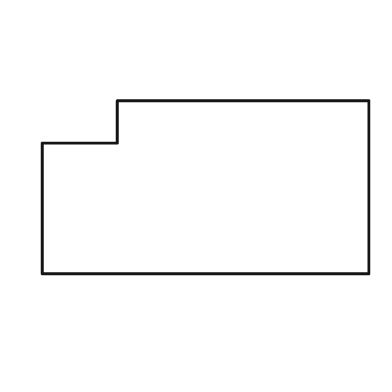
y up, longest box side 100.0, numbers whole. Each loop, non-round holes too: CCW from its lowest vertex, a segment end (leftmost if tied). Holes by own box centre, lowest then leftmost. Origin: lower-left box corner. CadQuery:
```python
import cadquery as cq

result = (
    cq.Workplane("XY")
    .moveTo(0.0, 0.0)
    .lineTo(100.0, 0.0)
    .lineTo(100.0, 53.0)
    .lineTo(23.0, 53.0)
    .lineTo(23.0, 40.0)
    .lineTo(0.0, 40.0)
    .close()
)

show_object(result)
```